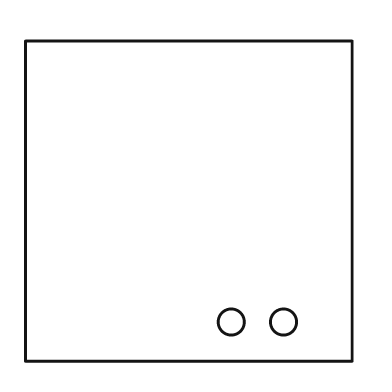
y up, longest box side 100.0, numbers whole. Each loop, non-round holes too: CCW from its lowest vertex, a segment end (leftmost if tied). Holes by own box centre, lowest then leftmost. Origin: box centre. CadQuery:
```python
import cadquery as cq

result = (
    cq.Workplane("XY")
    .moveTo(-50.0, -49.0)
    .lineTo(50.0, -49.0)
    .lineTo(50.0, 49.0)
    .lineTo(-50.0, 49.0)
    .close()
    .moveTo(13.0, -37.0)
    .circle(4.0)
    .moveTo(29.0, -37.0)
    .circle(4.0)
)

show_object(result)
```